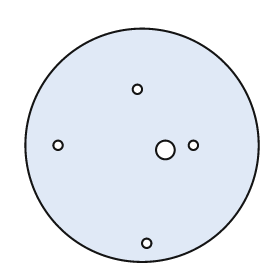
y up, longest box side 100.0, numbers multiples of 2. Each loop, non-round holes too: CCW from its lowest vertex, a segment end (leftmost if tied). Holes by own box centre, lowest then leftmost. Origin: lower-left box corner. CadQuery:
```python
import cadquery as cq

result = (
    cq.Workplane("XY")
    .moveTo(50.0, 50.0)
    .circle(50.0)
    .moveTo(52.0, 8.0)
    .circle(2.0)
    .moveTo(60.0, 48.0)
    .circle(4.0)
    .moveTo(14.0, 50.0)
    .circle(2.0)
    .moveTo(72.0, 50.0)
    .circle(2.0)
    .moveTo(48.0, 74.0)
    .circle(2.0)
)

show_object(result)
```